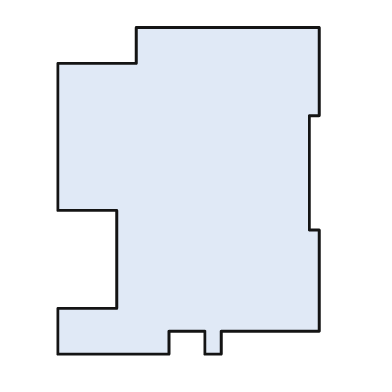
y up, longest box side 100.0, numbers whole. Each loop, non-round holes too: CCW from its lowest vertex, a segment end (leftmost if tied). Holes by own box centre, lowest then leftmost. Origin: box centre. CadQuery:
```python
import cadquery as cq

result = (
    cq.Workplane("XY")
    .moveTo(-40.0, -50.0)
    .lineTo(-6.0, -50.0)
    .lineTo(-6.0, -43.0)
    .lineTo(5.0, -43.0)
    .lineTo(5.0, -50.0)
    .lineTo(10.0, -50.0)
    .lineTo(10.0, -43.0)
    .lineTo(40.0, -43.0)
    .lineTo(40.0, -12.0)
    .lineTo(37.0, -12.0)
    .lineTo(37.0, 23.0)
    .lineTo(40.0, 23.0)
    .lineTo(40.0, 50.0)
    .lineTo(-16.0, 50.0)
    .lineTo(-16.0, 39.0)
    .lineTo(-40.0, 39.0)
    .lineTo(-40.0, -6.0)
    .lineTo(-22.0, -6.0)
    .lineTo(-22.0, -36.0)
    .lineTo(-40.0, -36.0)
    .close()
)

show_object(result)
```